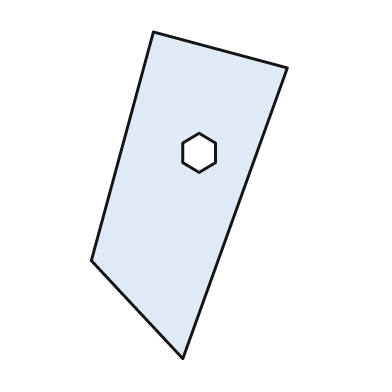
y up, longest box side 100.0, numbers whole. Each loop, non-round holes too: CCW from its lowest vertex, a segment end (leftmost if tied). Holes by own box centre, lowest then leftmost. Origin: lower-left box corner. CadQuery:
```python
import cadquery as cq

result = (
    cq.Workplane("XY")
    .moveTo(28.0, 0.0)
    .lineTo(60.0, 89.0)
    .lineTo(19.0, 100.0)
    .lineTo(0.0, 30.0)
    .close()
    .moveTo(33.0, 57.0)
    .lineTo(38.0, 60.0)
    .lineTo(38.0, 66.0)
    .lineTo(33.0, 69.0)
    .lineTo(28.0, 66.0)
    .lineTo(28.0, 60.0)
    .close()
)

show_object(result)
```